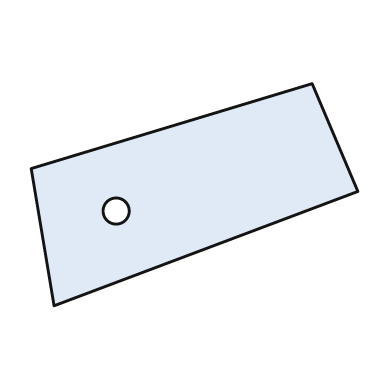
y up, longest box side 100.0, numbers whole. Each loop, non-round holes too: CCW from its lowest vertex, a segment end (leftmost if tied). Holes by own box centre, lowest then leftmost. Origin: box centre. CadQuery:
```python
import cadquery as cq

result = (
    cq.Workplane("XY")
    .moveTo(-43.0, -34.0)
    .lineTo(50.0, 1.0)
    .lineTo(36.0, 34.0)
    .lineTo(-50.0, 8.0)
    .close()
    .moveTo(-24.0, -5.0)
    .circle(4.0)
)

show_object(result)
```